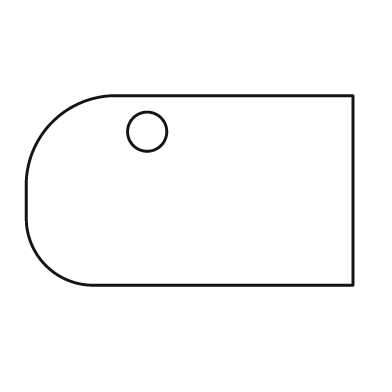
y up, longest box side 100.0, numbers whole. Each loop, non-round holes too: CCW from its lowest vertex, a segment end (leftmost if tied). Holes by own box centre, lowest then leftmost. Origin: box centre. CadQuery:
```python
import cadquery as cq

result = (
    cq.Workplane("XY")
    .moveTo(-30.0, -29.0)
    .lineTo(50.0, -29.0)
    .lineTo(50.0, 29.0)
    .lineTo(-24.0, 29.0)
    .threePointArc((-42.0, 21.0), (-50.0, 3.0))
    .lineTo(-50.0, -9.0)
    .threePointArc((-44.0, -23.0), (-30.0, -29.0))
    .close()
    .moveTo(-13.0, 18.0)
    .circle(6.0)
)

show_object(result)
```